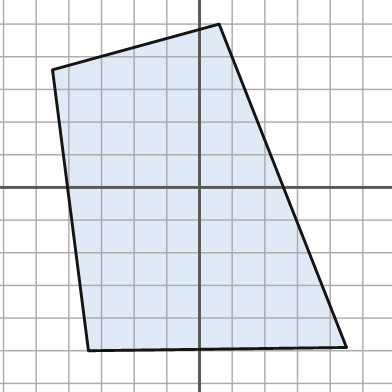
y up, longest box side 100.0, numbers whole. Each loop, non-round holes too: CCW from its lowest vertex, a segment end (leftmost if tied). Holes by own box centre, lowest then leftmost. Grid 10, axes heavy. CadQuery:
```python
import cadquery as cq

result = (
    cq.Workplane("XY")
    .moveTo(-34.0, -50.0)
    .lineTo(45.0, -49.0)
    .lineTo(6.0, 50.0)
    .lineTo(-45.0, 36.0)
    .close()
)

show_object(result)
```